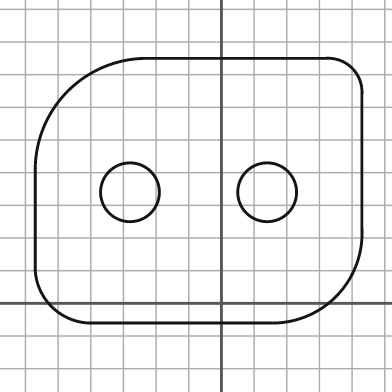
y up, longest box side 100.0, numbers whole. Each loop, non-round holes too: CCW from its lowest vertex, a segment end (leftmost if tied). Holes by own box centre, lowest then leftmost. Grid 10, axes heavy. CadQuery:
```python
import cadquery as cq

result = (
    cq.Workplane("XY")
    .moveTo(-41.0, -6.0)
    .lineTo(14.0, -6.0)
    .threePointArc((35.0, 2.0), (43.0, 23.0))
    .lineTo(43.0, 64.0)
    .threePointArc((40.0, 72.0), (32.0, 75.0))
    .lineTo(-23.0, 75.0)
    .threePointArc((-47.0, 65.0), (-57.0, 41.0))
    .lineTo(-57.0, 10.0)
    .threePointArc((-52.0, -1.0), (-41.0, -6.0))
    .close()
    .moveTo(-28.0, 34.0)
    .circle(9.0)
    .moveTo(14.0, 34.0)
    .circle(9.0)
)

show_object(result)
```